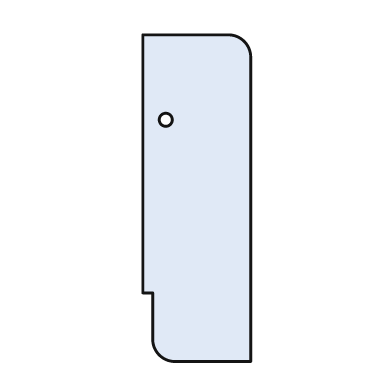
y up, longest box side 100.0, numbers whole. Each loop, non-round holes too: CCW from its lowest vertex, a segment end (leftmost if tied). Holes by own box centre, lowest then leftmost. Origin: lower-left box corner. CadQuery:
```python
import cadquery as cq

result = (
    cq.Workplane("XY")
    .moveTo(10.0, 0.0)
    .lineTo(33.0, 0.0)
    .lineTo(33.0, 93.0)
    .threePointArc((31.0, 98.0), (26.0, 100.0))
    .lineTo(0.0, 100.0)
    .lineTo(0.0, 21.0)
    .lineTo(3.0, 21.0)
    .lineTo(3.0, 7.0)
    .threePointArc((5.0, 2.0), (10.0, 0.0))
    .close()
    .moveTo(7.0, 74.0)
    .circle(2.0)
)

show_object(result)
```